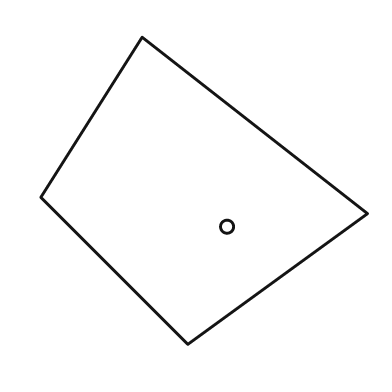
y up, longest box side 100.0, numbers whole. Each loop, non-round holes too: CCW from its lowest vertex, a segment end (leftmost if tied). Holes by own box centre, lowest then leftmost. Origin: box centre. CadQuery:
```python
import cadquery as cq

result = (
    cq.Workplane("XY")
    .moveTo(-5.0, -47.0)
    .lineTo(50.0, -7.0)
    .lineTo(-19.0, 47.0)
    .lineTo(-50.0, -2.0)
    .close()
    .moveTo(7.0, -11.0)
    .circle(2.0)
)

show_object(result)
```